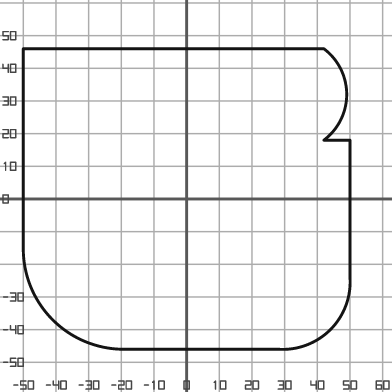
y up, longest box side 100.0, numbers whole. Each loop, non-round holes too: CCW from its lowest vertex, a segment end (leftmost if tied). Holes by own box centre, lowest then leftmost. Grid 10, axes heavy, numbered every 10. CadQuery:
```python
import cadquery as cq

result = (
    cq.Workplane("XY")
    .moveTo(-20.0, -46.0)
    .lineTo(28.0, -46.0)
    .threePointArc((44.0, -40.0), (50.0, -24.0))
    .lineTo(50.0, 18.0)
    .lineTo(42.0, 18.0)
    .threePointArc((49.0, 32.0), (42.0, 46.0))
    .lineTo(-50.0, 46.0)
    .lineTo(-50.0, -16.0)
    .threePointArc((-41.0, -37.0), (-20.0, -46.0))
    .close()
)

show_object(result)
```